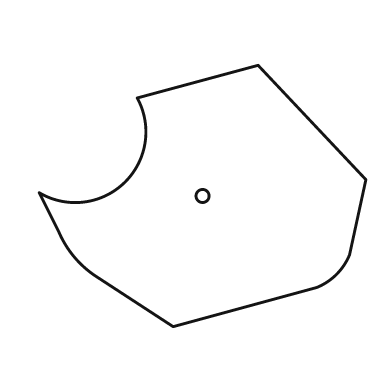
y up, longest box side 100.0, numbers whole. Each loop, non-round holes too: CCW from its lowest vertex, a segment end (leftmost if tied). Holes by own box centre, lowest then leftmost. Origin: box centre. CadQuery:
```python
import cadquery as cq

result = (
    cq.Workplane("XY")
    .moveTo(-9.0, -40.0)
    .lineTo(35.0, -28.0)
    .threePointArc((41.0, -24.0), (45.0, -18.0))
    .lineTo(50.0, 5.0)
    .lineTo(17.0, 40.0)
    .lineTo(-20.0, 30.0)
    .threePointArc((-24.0, 4.0), (-50.0, 1.0))
    .lineTo(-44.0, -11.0)
    .threePointArc((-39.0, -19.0), (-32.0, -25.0))
    .close()
    .moveTo(0.0, 0.0)
    .circle(2.0)
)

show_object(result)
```